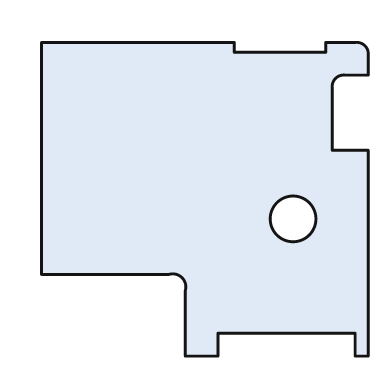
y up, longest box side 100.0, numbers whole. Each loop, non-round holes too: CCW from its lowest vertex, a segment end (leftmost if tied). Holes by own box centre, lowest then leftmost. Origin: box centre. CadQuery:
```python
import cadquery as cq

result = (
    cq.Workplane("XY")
    .moveTo(-6.0, -48.0)
    .lineTo(4.0, -48.0)
    .lineTo(4.0, -41.0)
    .lineTo(46.0, -41.0)
    .lineTo(46.0, -48.0)
    .lineTo(50.0, -48.0)
    .lineTo(50.0, 15.0)
    .lineTo(39.0, 15.0)
    .lineTo(39.0, 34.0)
    .threePointArc((40.0, 37.0), (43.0, 38.0))
    .lineTo(50.0, 38.0)
    .lineTo(50.0, 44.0)
    .threePointArc((49.0, 47.0), (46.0, 48.0))
    .lineTo(37.0, 48.0)
    .lineTo(37.0, 45.0)
    .lineTo(9.0, 45.0)
    .lineTo(9.0, 48.0)
    .lineTo(-50.0, 48.0)
    .lineTo(-50.0, -23.0)
    .lineTo(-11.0, -23.0)
    .threePointArc((-7.0, -24.0), (-6.0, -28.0))
    .close()
    .moveTo(27.0, -6.0)
    .circle(7.0)
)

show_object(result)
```